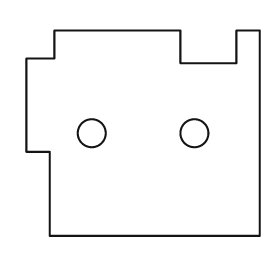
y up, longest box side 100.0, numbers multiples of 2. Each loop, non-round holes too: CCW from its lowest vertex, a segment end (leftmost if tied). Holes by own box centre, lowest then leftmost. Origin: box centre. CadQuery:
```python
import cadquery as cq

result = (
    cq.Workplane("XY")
    .moveTo(-40.0, -44.0)
    .lineTo(50.0, -44.0)
    .lineTo(50.0, 44.0)
    .lineTo(40.0, 44.0)
    .lineTo(40.0, 30.0)
    .lineTo(16.0, 30.0)
    .lineTo(16.0, 44.0)
    .lineTo(-38.0, 44.0)
    .lineTo(-38.0, 32.0)
    .lineTo(-50.0, 32.0)
    .lineTo(-50.0, -8.0)
    .lineTo(-40.0, -8.0)
    .close()
    .moveTo(-22.0, 0.0)
    .circle(6.0)
    .moveTo(22.0, 0.0)
    .circle(6.0)
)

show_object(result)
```